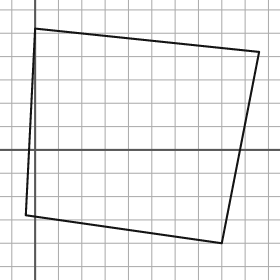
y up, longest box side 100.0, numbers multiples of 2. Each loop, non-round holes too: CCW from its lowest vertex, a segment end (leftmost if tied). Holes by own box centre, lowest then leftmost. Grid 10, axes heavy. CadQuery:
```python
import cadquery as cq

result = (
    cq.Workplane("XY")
    .moveTo(80.0, -40.0)
    .lineTo(96.0, 42.0)
    .lineTo(0.0, 52.0)
    .lineTo(-4.0, -28.0)
    .close()
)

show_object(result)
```